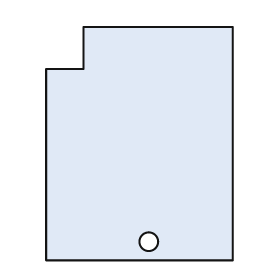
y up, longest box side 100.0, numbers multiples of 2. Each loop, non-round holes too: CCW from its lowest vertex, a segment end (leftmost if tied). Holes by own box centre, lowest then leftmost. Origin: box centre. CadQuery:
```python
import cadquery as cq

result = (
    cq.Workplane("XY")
    .moveTo(-40.0, -50.0)
    .lineTo(40.0, -50.0)
    .lineTo(40.0, 50.0)
    .lineTo(-24.0, 50.0)
    .lineTo(-24.0, 32.0)
    .lineTo(-40.0, 32.0)
    .close()
    .moveTo(4.0, -42.0)
    .circle(4.0)
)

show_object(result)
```